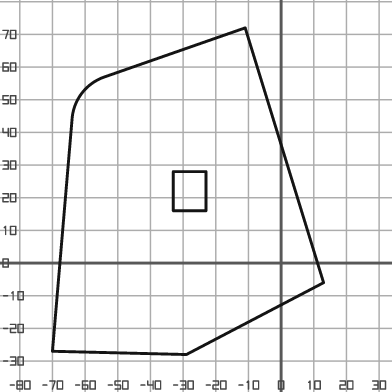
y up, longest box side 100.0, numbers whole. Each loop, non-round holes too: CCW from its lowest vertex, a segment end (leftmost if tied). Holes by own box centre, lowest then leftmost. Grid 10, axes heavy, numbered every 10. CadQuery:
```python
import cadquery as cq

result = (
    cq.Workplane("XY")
    .moveTo(-29.0, -28.0)
    .lineTo(13.0, -6.0)
    .lineTo(-11.0, 72.0)
    .lineTo(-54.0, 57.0)
    .threePointArc((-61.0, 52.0), (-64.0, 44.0))
    .lineTo(-70.0, -27.0)
    .close()
    .moveTo(-33.0, 16.0)
    .lineTo(-23.0, 16.0)
    .lineTo(-23.0, 28.0)
    .lineTo(-33.0, 28.0)
    .close()
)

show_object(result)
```